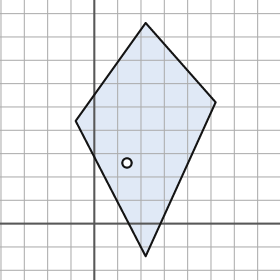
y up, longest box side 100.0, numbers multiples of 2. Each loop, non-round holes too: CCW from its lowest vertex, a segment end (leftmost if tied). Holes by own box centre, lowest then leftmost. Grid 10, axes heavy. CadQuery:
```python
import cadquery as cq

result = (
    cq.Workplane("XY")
    .moveTo(22.0, -14.0)
    .lineTo(52.0, 52.0)
    .lineTo(22.0, 86.0)
    .lineTo(-8.0, 44.0)
    .close()
    .moveTo(14.0, 26.0)
    .circle(2.0)
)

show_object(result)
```